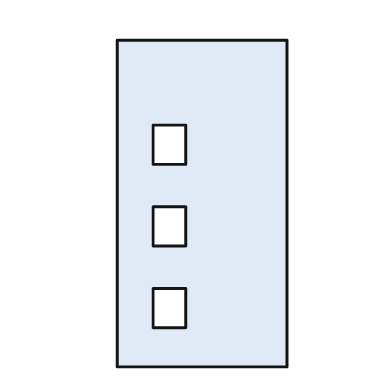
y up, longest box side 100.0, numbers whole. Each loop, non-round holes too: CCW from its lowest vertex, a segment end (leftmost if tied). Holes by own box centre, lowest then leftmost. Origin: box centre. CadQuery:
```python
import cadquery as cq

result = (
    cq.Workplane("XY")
    .moveTo(-26.0, -50.0)
    .lineTo(26.0, -50.0)
    .lineTo(26.0, 50.0)
    .lineTo(-26.0, 50.0)
    .close()
    .moveTo(-15.0, -38.0)
    .lineTo(-5.0, -38.0)
    .lineTo(-5.0, -26.0)
    .lineTo(-15.0, -26.0)
    .close()
    .moveTo(-15.0, -13.0)
    .lineTo(-5.0, -13.0)
    .lineTo(-5.0, -1.0)
    .lineTo(-15.0, -1.0)
    .close()
    .moveTo(-15.0, 12.0)
    .lineTo(-5.0, 12.0)
    .lineTo(-5.0, 24.0)
    .lineTo(-15.0, 24.0)
    .close()
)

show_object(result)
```